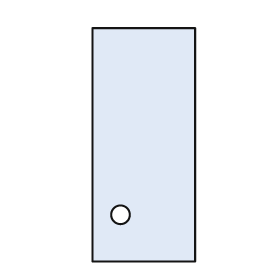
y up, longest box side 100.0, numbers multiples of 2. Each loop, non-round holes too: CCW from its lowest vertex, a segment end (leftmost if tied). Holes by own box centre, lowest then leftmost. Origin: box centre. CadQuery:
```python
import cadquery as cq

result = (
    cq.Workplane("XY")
    .moveTo(-22.0, -50.0)
    .lineTo(22.0, -50.0)
    .lineTo(22.0, 50.0)
    .lineTo(-22.0, 50.0)
    .close()
    .moveTo(-10.0, -30.0)
    .circle(4.0)
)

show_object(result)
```